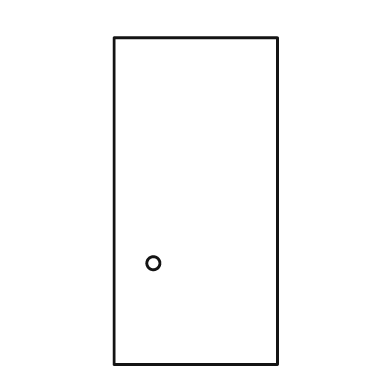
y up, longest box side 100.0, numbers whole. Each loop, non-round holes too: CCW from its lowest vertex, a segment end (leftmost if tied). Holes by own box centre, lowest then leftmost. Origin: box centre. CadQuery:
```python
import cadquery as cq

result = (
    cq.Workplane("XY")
    .moveTo(-25.0, -50.0)
    .lineTo(25.0, -50.0)
    .lineTo(25.0, 50.0)
    .lineTo(-25.0, 50.0)
    .close()
    .moveTo(-13.0, -19.0)
    .circle(2.0)
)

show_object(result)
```